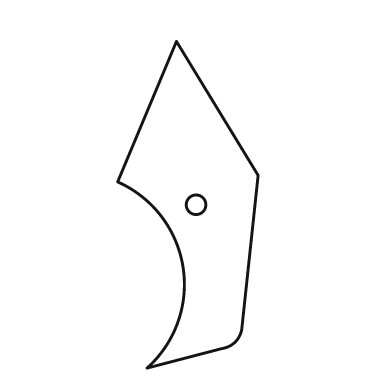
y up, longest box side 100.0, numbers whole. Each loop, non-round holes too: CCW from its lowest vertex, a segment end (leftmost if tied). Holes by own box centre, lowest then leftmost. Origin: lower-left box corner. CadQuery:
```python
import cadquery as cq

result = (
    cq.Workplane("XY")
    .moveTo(9.0, 0.0)
    .lineTo(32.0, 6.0)
    .threePointArc((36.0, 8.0), (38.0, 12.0))
    .lineTo(43.0, 59.0)
    .lineTo(18.0, 100.0)
    .lineTo(0.0, 57.0)
    .threePointArc((20.0, 31.0), (9.0, 0.0))
    .close()
    .moveTo(24.0, 50.0)
    .circle(3.0)
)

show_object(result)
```